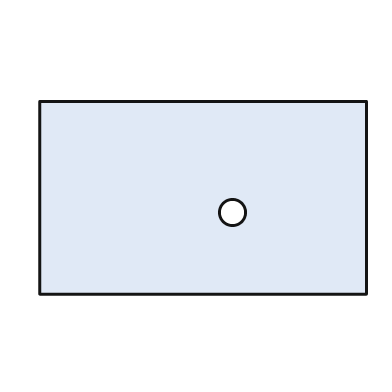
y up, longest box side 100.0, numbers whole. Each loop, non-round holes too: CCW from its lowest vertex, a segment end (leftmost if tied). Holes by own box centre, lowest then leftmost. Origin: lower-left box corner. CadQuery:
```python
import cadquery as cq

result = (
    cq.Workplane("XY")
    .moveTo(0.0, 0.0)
    .lineTo(100.0, 0.0)
    .lineTo(100.0, 59.0)
    .lineTo(0.0, 59.0)
    .close()
    .moveTo(59.0, 25.0)
    .circle(4.0)
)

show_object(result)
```